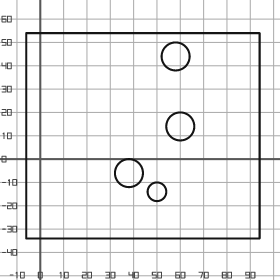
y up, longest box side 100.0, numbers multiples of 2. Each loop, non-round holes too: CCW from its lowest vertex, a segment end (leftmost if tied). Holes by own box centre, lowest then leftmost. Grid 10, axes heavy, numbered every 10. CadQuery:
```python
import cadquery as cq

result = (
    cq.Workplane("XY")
    .moveTo(-6.0, -34.0)
    .lineTo(94.0, -34.0)
    .lineTo(94.0, 54.0)
    .lineTo(-6.0, 54.0)
    .close()
    .moveTo(50.0, -14.0)
    .circle(4.0)
    .moveTo(38.0, -6.0)
    .circle(6.0)
    .moveTo(60.0, 14.0)
    .circle(6.0)
    .moveTo(58.0, 44.0)
    .circle(6.0)
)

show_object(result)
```